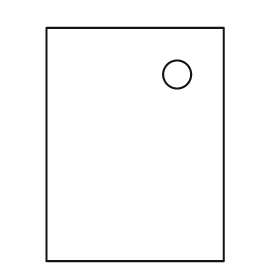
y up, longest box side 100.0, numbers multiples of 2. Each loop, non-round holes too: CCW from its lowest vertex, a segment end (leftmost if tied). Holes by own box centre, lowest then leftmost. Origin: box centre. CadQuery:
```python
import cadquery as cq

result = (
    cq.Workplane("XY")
    .moveTo(-38.0, -50.0)
    .lineTo(38.0, -50.0)
    .lineTo(38.0, 50.0)
    .lineTo(-38.0, 50.0)
    .close()
    .moveTo(18.0, 30.0)
    .circle(6.0)
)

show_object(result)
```